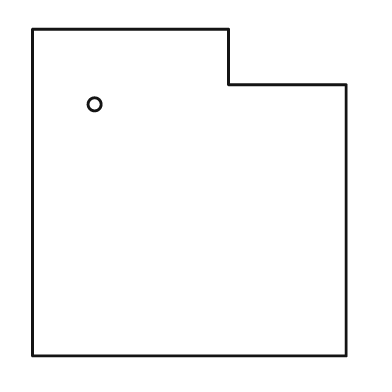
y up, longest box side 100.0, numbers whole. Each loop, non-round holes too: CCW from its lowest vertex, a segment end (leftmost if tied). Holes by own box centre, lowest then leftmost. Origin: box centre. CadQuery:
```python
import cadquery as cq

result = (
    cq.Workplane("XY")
    .moveTo(-48.0, -50.0)
    .lineTo(48.0, -50.0)
    .lineTo(48.0, 33.0)
    .lineTo(12.0, 33.0)
    .lineTo(12.0, 50.0)
    .lineTo(-48.0, 50.0)
    .close()
    .moveTo(-29.0, 27.0)
    .circle(2.0)
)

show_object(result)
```